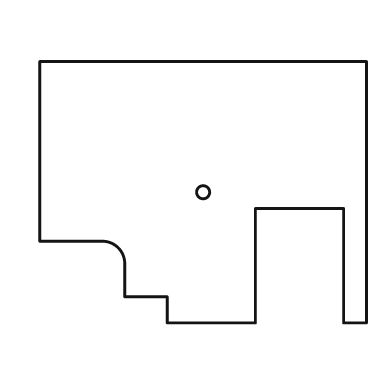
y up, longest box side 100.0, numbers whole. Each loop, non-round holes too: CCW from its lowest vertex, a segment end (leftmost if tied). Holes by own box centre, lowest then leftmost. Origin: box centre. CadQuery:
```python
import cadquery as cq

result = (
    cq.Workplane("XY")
    .moveTo(-11.0, -40.0)
    .lineTo(16.0, -40.0)
    .lineTo(16.0, -5.0)
    .lineTo(43.0, -5.0)
    .lineTo(43.0, -40.0)
    .lineTo(50.0, -40.0)
    .lineTo(50.0, 40.0)
    .lineTo(-50.0, 40.0)
    .lineTo(-50.0, -15.0)
    .lineTo(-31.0, -15.0)
    .threePointArc((-26.0, -17.0), (-24.0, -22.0))
    .lineTo(-24.0, -32.0)
    .lineTo(-11.0, -32.0)
    .close()
    .moveTo(0.0, 0.0)
    .circle(2.0)
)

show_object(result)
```